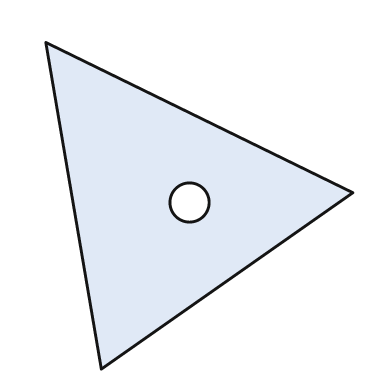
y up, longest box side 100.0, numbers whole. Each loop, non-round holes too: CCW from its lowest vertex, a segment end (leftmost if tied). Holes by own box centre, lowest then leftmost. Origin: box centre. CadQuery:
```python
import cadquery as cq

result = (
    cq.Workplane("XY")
    .moveTo(-30.0, -50.0)
    .lineTo(47.0, 4.0)
    .lineTo(-47.0, 50.0)
    .close()
    .moveTo(-3.0, 1.0)
    .circle(6.0)
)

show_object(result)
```